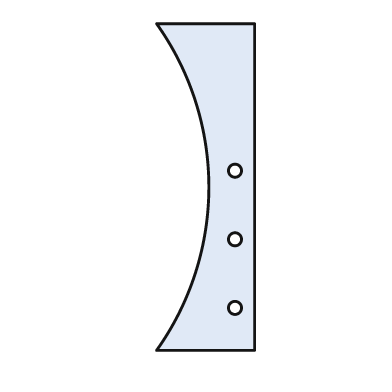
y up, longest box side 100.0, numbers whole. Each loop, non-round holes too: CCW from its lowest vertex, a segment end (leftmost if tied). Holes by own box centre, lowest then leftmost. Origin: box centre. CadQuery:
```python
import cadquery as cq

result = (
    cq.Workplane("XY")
    .moveTo(-15.0, -50.0)
    .lineTo(15.0, -50.0)
    .lineTo(15.0, 50.0)
    .lineTo(-15.0, 50.0)
    .threePointArc((1.0, 0.0), (-15.0, -50.0))
    .close()
    .moveTo(9.0, -37.0)
    .circle(2.0)
    .moveTo(9.0, -16.0)
    .circle(2.0)
    .moveTo(9.0, 5.0)
    .circle(2.0)
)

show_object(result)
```